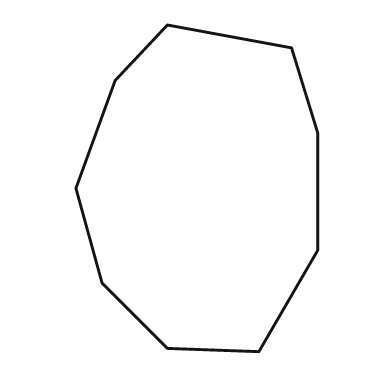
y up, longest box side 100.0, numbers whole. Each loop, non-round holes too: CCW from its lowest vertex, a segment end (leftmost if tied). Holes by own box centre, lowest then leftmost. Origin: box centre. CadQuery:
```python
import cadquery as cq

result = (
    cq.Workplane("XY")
    .moveTo(19.0, -50.0)
    .lineTo(37.0, -19.0)
    .lineTo(37.0, 17.0)
    .lineTo(29.0, 43.0)
    .lineTo(-9.0, 50.0)
    .lineTo(-25.0, 33.0)
    .lineTo(-37.0, 0.0)
    .lineTo(-29.0, -29.0)
    .lineTo(-9.0, -49.0)
    .close()
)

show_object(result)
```